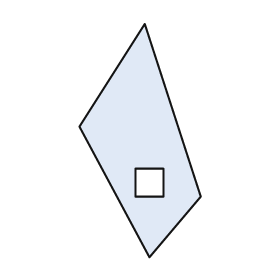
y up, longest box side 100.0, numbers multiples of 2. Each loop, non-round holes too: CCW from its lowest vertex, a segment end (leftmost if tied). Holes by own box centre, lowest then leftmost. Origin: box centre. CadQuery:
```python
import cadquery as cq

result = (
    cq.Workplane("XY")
    .moveTo(4.0, -50.0)
    .lineTo(26.0, -24.0)
    .lineTo(2.0, 50.0)
    .lineTo(-26.0, 6.0)
    .close()
    .moveTo(-2.0, -24.0)
    .lineTo(10.0, -24.0)
    .lineTo(10.0, -12.0)
    .lineTo(-2.0, -12.0)
    .close()
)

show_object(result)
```